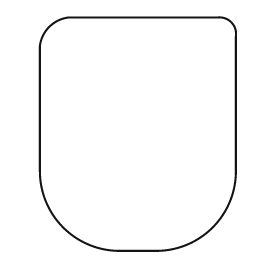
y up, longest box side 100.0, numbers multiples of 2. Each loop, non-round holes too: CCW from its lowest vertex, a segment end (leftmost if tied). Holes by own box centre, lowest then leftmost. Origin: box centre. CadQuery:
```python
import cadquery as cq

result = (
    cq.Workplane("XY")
    .moveTo(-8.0, -50.0)
    .lineTo(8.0, -50.0)
    .threePointArc((32.0, -40.0), (42.0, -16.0))
    .lineTo(42.0, 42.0)
    .threePointArc((40.0, 48.0), (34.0, 50.0))
    .lineTo(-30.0, 50.0)
    .threePointArc((-38.0, 46.0), (-42.0, 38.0))
    .lineTo(-42.0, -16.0)
    .threePointArc((-32.0, -40.0), (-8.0, -50.0))
    .close()
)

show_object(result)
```